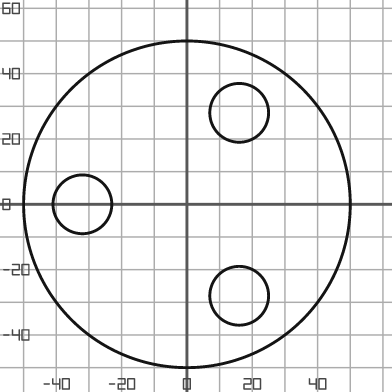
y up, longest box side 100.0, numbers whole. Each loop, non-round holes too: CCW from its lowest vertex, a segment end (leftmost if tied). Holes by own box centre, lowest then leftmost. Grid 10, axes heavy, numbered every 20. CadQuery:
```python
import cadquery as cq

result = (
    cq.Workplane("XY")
    .moveTo(0.0, 0.0)
    .circle(50.0)
    .moveTo(16.0, -28.0)
    .circle(9.0)
    .moveTo(-32.0, 0.0)
    .circle(9.0)
    .moveTo(16.0, 28.0)
    .circle(9.0)
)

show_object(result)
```